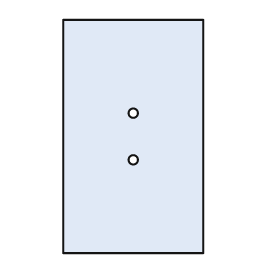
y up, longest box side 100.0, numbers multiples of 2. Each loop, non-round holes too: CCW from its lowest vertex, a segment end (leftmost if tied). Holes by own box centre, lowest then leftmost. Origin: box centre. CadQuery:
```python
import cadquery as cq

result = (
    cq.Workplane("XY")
    .moveTo(-30.0, -50.0)
    .lineTo(30.0, -50.0)
    .lineTo(30.0, 50.0)
    .lineTo(-30.0, 50.0)
    .close()
    .moveTo(0.0, -10.0)
    .circle(2.0)
    .moveTo(0.0, 10.0)
    .circle(2.0)
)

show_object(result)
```